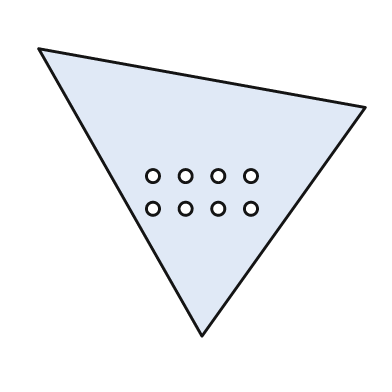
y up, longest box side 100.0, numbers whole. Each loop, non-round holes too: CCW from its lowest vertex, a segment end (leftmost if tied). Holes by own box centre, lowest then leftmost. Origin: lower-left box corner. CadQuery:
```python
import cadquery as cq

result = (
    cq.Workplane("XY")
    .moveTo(50.0, 0.0)
    .lineTo(100.0, 70.0)
    .lineTo(0.0, 88.0)
    .close()
    .moveTo(35.0, 39.0)
    .circle(2.0)
    .moveTo(45.0, 39.0)
    .circle(2.0)
    .moveTo(55.0, 39.0)
    .circle(2.0)
    .moveTo(65.0, 39.0)
    .circle(2.0)
    .moveTo(35.0, 49.0)
    .circle(2.0)
    .moveTo(45.0, 49.0)
    .circle(2.0)
    .moveTo(55.0, 49.0)
    .circle(2.0)
    .moveTo(65.0, 49.0)
    .circle(2.0)
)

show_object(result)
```